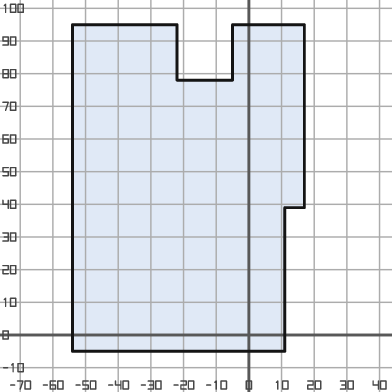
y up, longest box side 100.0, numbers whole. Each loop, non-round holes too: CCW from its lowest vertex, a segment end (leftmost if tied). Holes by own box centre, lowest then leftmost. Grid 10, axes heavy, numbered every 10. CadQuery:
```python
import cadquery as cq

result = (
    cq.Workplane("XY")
    .moveTo(-54.0, -5.0)
    .lineTo(11.0, -5.0)
    .lineTo(11.0, 39.0)
    .lineTo(17.0, 39.0)
    .lineTo(17.0, 95.0)
    .lineTo(-5.0, 95.0)
    .lineTo(-5.0, 78.0)
    .lineTo(-22.0, 78.0)
    .lineTo(-22.0, 95.0)
    .lineTo(-54.0, 95.0)
    .close()
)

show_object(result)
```